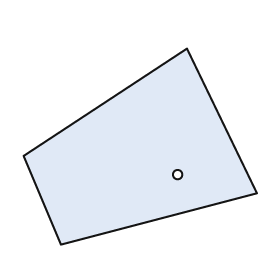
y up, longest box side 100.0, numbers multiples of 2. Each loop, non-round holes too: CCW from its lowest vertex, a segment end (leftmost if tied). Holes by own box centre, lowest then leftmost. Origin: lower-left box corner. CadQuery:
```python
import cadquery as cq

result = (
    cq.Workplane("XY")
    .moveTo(16.0, 0.0)
    .lineTo(100.0, 22.0)
    .lineTo(70.0, 84.0)
    .lineTo(0.0, 38.0)
    .close()
    .moveTo(66.0, 30.0)
    .circle(2.0)
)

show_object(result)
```